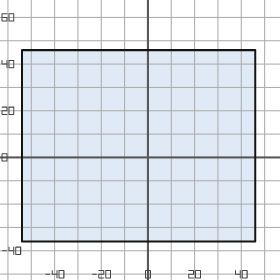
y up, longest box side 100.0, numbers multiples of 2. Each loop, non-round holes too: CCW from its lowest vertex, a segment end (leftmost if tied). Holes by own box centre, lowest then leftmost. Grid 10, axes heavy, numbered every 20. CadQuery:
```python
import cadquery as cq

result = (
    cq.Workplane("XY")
    .moveTo(-54.0, -36.0)
    .lineTo(46.0, -36.0)
    .lineTo(46.0, 46.0)
    .lineTo(-54.0, 46.0)
    .close()
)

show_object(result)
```